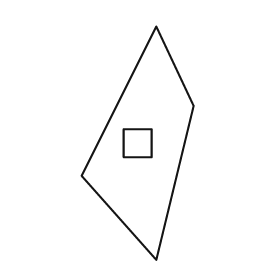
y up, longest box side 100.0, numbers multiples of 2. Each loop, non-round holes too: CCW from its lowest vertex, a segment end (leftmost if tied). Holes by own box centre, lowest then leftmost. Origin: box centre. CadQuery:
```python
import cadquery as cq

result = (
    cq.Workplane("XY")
    .moveTo(8.0, -50.0)
    .lineTo(24.0, 16.0)
    .lineTo(8.0, 50.0)
    .lineTo(-24.0, -14.0)
    .close()
    .moveTo(-6.0, -6.0)
    .lineTo(6.0, -6.0)
    .lineTo(6.0, 6.0)
    .lineTo(-6.0, 6.0)
    .close()
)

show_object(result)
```